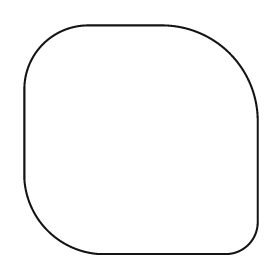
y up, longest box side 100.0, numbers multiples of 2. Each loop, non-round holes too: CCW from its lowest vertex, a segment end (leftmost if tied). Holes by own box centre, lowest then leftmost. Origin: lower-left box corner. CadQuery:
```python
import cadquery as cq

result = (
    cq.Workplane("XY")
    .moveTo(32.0, 0.0)
    .lineTo(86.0, 0.0)
    .threePointArc((96.0, 4.0), (100.0, 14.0))
    .lineTo(100.0, 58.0)
    .threePointArc((88.0, 86.0), (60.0, 98.0))
    .lineTo(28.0, 98.0)
    .threePointArc((8.0, 90.0), (0.0, 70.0))
    .lineTo(0.0, 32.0)
    .threePointArc((10.0, 10.0), (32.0, 0.0))
    .close()
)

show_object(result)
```